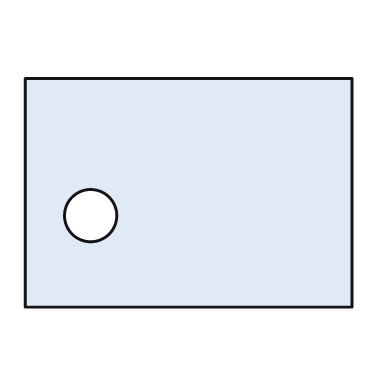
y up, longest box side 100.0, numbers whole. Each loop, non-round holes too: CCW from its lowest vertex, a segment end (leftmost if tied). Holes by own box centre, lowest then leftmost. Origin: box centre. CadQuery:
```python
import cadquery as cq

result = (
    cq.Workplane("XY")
    .moveTo(-50.0, -35.0)
    .lineTo(50.0, -35.0)
    .lineTo(50.0, 35.0)
    .lineTo(-50.0, 35.0)
    .close()
    .moveTo(-30.0, -7.0)
    .circle(8.0)
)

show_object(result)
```